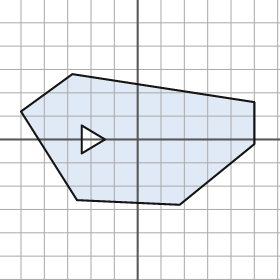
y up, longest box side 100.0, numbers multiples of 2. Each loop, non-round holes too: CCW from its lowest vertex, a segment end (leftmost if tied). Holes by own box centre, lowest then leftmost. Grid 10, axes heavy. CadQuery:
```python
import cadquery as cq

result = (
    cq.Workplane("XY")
    .moveTo(18.0, -28.0)
    .lineTo(50.0, -2.0)
    .lineTo(50.0, 16.0)
    .lineTo(-28.0, 28.0)
    .lineTo(-50.0, 12.0)
    .lineTo(-26.0, -26.0)
    .close()
    .moveTo(-24.0, -6.0)
    .lineTo(-14.0, 0.0)
    .lineTo(-24.0, 6.0)
    .close()
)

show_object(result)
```